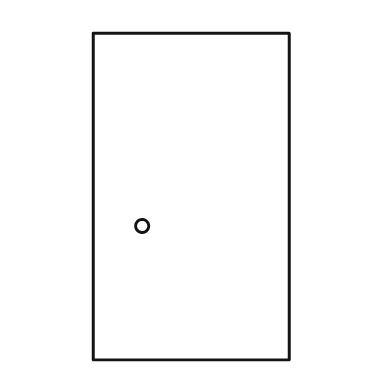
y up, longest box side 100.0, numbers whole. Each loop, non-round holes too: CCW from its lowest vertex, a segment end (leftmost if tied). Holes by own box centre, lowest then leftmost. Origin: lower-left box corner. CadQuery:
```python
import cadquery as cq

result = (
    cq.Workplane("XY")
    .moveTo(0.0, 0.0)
    .lineTo(60.0, 0.0)
    .lineTo(60.0, 100.0)
    .lineTo(0.0, 100.0)
    .close()
    .moveTo(15.0, 41.0)
    .circle(2.0)
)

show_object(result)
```